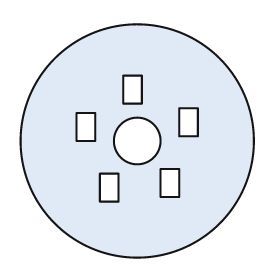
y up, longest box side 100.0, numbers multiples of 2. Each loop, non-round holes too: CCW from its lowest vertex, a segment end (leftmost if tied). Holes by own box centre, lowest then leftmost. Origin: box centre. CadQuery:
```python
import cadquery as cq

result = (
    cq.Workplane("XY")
    .moveTo(0.0, 0.0)
    .circle(50.0)
    .moveTo(-16.0, -26.0)
    .lineTo(-8.0, -26.0)
    .lineTo(-8.0, -14.0)
    .lineTo(-16.0, -14.0)
    .close()
    .moveTo(10.0, -24.0)
    .lineTo(18.0, -24.0)
    .lineTo(18.0, -12.0)
    .lineTo(10.0, -12.0)
    .close()
    .moveTo(0.0, 0.0)
    .circle(10.0)
    .moveTo(-26.0, 0.0)
    .lineTo(-18.0, 0.0)
    .lineTo(-18.0, 12.0)
    .lineTo(-26.0, 12.0)
    .close()
    .moveTo(18.0, 2.0)
    .lineTo(26.0, 2.0)
    .lineTo(26.0, 14.0)
    .lineTo(18.0, 14.0)
    .close()
    .moveTo(-6.0, 16.0)
    .lineTo(2.0, 16.0)
    .lineTo(2.0, 28.0)
    .lineTo(-6.0, 28.0)
    .close()
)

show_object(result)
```